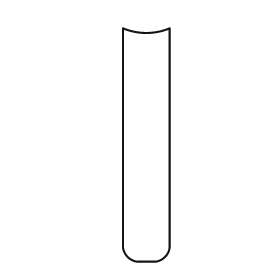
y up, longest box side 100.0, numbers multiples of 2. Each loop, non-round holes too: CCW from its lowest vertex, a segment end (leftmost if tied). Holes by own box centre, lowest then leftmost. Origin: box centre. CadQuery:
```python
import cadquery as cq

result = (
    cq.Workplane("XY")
    .moveTo(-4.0, -50.0)
    .lineTo(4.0, -50.0)
    .threePointArc((8.0, -48.0), (10.0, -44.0))
    .lineTo(10.0, 50.0)
    .threePointArc((0.0, 48.0), (-10.0, 50.0))
    .lineTo(-10.0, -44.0)
    .threePointArc((-8.0, -48.0), (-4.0, -50.0))
    .close()
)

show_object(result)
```